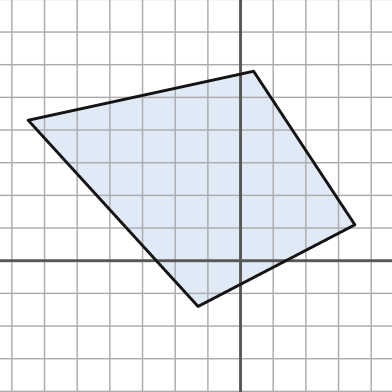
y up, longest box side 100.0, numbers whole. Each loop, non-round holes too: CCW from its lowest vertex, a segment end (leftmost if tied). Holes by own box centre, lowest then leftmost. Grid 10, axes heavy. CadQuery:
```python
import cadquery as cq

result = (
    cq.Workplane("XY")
    .moveTo(-13.0, -14.0)
    .lineTo(35.0, 11.0)
    .lineTo(4.0, 58.0)
    .lineTo(-65.0, 43.0)
    .close()
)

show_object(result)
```